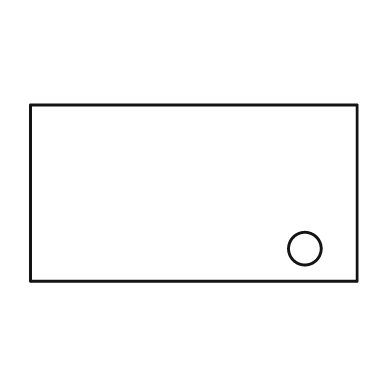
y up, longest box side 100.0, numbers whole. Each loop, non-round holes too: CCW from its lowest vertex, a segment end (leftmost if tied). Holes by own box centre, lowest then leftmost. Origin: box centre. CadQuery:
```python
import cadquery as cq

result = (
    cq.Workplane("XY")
    .moveTo(-50.0, -27.0)
    .lineTo(50.0, -27.0)
    .lineTo(50.0, 27.0)
    .lineTo(-50.0, 27.0)
    .close()
    .moveTo(34.0, -17.0)
    .circle(5.0)
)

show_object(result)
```